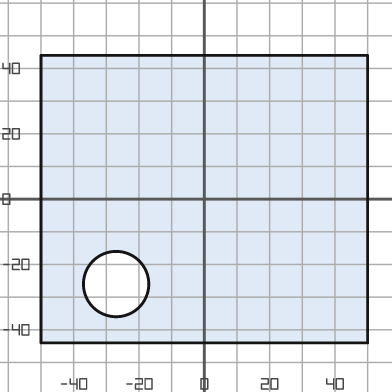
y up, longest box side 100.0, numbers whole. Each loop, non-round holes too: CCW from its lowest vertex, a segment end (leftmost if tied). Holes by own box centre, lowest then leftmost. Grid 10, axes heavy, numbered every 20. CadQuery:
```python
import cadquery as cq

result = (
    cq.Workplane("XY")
    .moveTo(-50.0, -44.0)
    .lineTo(50.0, -44.0)
    .lineTo(50.0, 44.0)
    .lineTo(-50.0, 44.0)
    .close()
    .moveTo(-27.0, -26.0)
    .circle(10.0)
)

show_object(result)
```